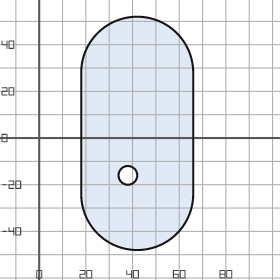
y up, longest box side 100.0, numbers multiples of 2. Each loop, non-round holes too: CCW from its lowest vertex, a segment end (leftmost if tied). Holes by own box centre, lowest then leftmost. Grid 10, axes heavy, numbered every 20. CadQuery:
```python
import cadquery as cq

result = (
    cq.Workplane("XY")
    .moveTo(18.0, -24.0)
    .threePointArc((42.0, -48.0), (66.0, -24.0))
    .lineTo(66.0, 28.0)
    .threePointArc((42.0, 52.0), (18.0, 28.0))
    .close()
    .moveTo(38.0, -16.0)
    .circle(4.0)
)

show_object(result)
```